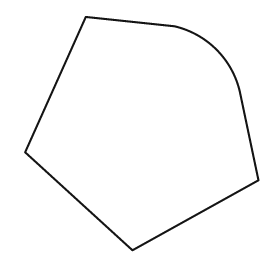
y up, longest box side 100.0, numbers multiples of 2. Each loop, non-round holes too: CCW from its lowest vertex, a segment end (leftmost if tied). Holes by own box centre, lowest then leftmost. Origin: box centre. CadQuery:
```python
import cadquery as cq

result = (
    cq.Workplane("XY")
    .moveTo(-4.0, -50.0)
    .lineTo(50.0, -20.0)
    .lineTo(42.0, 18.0)
    .threePointArc((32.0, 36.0), (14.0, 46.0))
    .lineTo(-24.0, 50.0)
    .lineTo(-50.0, -8.0)
    .close()
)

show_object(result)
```